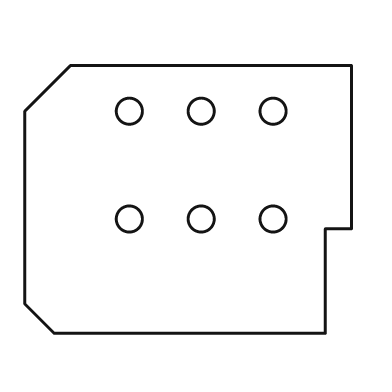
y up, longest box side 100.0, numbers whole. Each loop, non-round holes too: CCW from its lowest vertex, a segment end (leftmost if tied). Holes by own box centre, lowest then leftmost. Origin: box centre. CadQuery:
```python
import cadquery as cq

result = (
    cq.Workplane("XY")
    .moveTo(-41.0, -41.0)
    .lineTo(42.0, -41.0)
    .lineTo(42.0, -9.0)
    .lineTo(50.0, -9.0)
    .lineTo(50.0, 41.0)
    .lineTo(-36.0, 41.0)
    .lineTo(-50.0, 27.0)
    .lineTo(-50.0, -32.0)
    .close()
    .moveTo(-18.0, -6.0)
    .circle(4.0)
    .moveTo(4.0, -6.0)
    .circle(4.0)
    .moveTo(26.0, -6.0)
    .circle(4.0)
    .moveTo(-18.0, 27.0)
    .circle(4.0)
    .moveTo(4.0, 27.0)
    .circle(4.0)
    .moveTo(26.0, 27.0)
    .circle(4.0)
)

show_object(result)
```